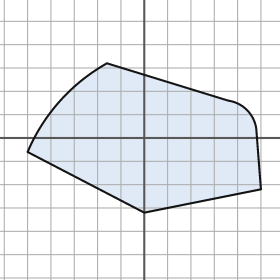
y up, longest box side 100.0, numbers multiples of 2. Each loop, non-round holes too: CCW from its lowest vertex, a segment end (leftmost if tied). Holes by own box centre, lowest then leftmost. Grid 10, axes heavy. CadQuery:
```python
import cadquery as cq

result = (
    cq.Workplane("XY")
    .moveTo(0.0, -32.0)
    .lineTo(50.0, -22.0)
    .lineTo(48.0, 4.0)
    .threePointArc((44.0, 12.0), (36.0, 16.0))
    .lineTo(-16.0, 32.0)
    .threePointArc((-36.0, 16.0), (-50.0, -6.0))
    .close()
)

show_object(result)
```